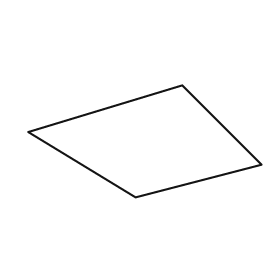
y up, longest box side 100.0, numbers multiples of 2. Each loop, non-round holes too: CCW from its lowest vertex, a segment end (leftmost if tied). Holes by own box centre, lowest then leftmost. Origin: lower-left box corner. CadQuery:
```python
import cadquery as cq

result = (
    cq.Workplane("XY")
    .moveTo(46.0, 0.0)
    .lineTo(100.0, 14.0)
    .lineTo(66.0, 48.0)
    .lineTo(0.0, 28.0)
    .close()
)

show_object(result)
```